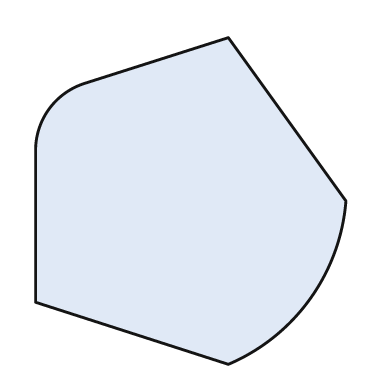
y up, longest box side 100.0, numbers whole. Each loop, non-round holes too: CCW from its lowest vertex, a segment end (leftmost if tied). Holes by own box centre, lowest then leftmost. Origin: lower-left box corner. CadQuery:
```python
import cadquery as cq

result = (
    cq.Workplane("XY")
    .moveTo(59.0, 0.0)
    .threePointArc((84.0, 20.0), (95.0, 50.0))
    .lineTo(59.0, 100.0)
    .lineTo(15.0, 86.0)
    .threePointArc((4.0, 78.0), (0.0, 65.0))
    .lineTo(0.0, 19.0)
    .close()
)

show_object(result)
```